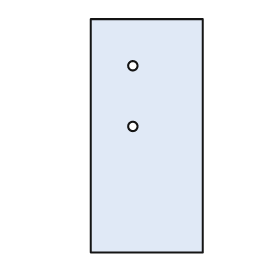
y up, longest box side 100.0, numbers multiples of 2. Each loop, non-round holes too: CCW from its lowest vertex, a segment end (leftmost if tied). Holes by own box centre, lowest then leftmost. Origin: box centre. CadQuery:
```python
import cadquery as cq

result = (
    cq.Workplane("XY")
    .moveTo(-24.0, -50.0)
    .lineTo(24.0, -50.0)
    .lineTo(24.0, 50.0)
    .lineTo(-24.0, 50.0)
    .close()
    .moveTo(-6.0, 4.0)
    .circle(2.0)
    .moveTo(-6.0, 30.0)
    .circle(2.0)
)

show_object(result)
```